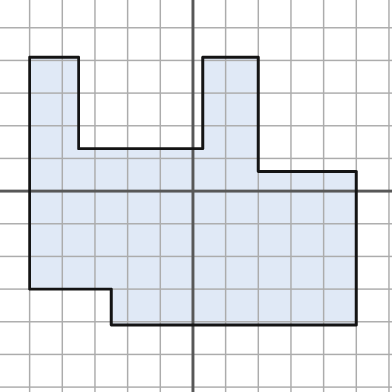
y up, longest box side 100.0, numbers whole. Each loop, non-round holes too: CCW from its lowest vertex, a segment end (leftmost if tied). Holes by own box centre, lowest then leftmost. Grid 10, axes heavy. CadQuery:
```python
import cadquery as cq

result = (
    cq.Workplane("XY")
    .moveTo(-25.0, -41.0)
    .lineTo(50.0, -41.0)
    .lineTo(50.0, 6.0)
    .lineTo(20.0, 6.0)
    .lineTo(20.0, 41.0)
    .lineTo(3.0, 41.0)
    .lineTo(3.0, 13.0)
    .lineTo(-35.0, 13.0)
    .lineTo(-35.0, 41.0)
    .lineTo(-50.0, 41.0)
    .lineTo(-50.0, -30.0)
    .lineTo(-25.0, -30.0)
    .close()
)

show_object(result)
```